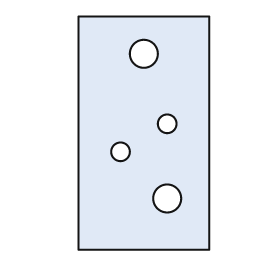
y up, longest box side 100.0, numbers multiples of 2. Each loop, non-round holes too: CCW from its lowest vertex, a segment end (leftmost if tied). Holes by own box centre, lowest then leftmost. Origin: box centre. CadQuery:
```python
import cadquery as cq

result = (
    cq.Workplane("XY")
    .moveTo(-28.0, -50.0)
    .lineTo(28.0, -50.0)
    .lineTo(28.0, 50.0)
    .lineTo(-28.0, 50.0)
    .close()
    .moveTo(10.0, -28.0)
    .circle(6.0)
    .moveTo(-10.0, -8.0)
    .circle(4.0)
    .moveTo(10.0, 4.0)
    .circle(4.0)
    .moveTo(0.0, 34.0)
    .circle(6.0)
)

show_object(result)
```